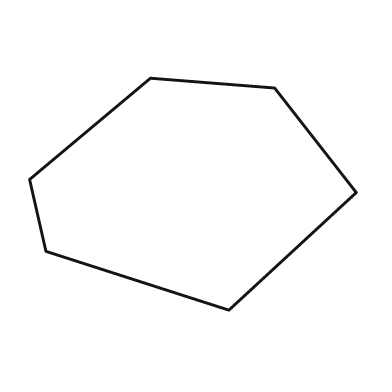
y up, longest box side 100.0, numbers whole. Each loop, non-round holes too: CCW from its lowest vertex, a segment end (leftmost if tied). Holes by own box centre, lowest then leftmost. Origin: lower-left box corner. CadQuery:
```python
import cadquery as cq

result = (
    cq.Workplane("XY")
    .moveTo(61.0, 0.0)
    .lineTo(100.0, 36.0)
    .lineTo(75.0, 68.0)
    .lineTo(37.0, 71.0)
    .lineTo(0.0, 40.0)
    .lineTo(5.0, 18.0)
    .close()
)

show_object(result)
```